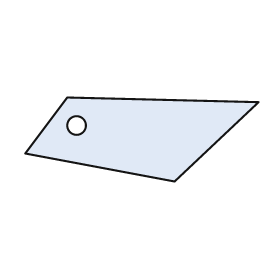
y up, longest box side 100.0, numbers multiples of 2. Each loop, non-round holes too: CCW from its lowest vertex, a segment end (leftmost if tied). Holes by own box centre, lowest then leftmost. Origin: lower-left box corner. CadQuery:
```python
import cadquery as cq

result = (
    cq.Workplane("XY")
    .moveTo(64.0, 0.0)
    .lineTo(100.0, 34.0)
    .lineTo(18.0, 36.0)
    .lineTo(0.0, 12.0)
    .close()
    .moveTo(22.0, 24.0)
    .circle(4.0)
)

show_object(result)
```